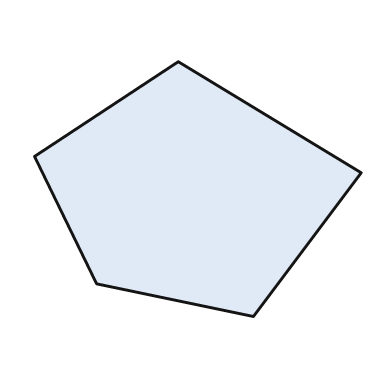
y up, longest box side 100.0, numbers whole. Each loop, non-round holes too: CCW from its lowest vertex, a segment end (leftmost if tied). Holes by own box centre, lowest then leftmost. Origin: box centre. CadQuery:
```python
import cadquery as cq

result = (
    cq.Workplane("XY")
    .moveTo(17.0, -39.0)
    .lineTo(50.0, 5.0)
    .lineTo(-6.0, 39.0)
    .lineTo(-50.0, 10.0)
    .lineTo(-31.0, -29.0)
    .close()
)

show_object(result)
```